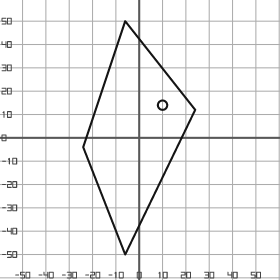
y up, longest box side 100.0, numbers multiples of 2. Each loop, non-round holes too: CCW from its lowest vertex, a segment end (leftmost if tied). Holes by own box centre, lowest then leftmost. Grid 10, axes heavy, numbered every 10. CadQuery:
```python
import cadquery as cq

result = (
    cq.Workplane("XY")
    .moveTo(-6.0, -50.0)
    .lineTo(24.0, 12.0)
    .lineTo(-6.0, 50.0)
    .lineTo(-24.0, -4.0)
    .close()
    .moveTo(10.0, 14.0)
    .circle(2.0)
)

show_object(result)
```